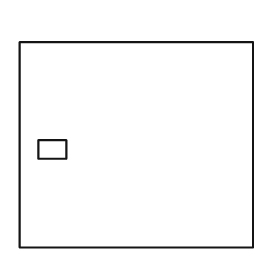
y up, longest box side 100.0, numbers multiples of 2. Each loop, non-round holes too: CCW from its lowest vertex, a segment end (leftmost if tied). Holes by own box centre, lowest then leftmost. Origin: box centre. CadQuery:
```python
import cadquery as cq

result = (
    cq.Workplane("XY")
    .moveTo(-50.0, -44.0)
    .lineTo(50.0, -44.0)
    .lineTo(50.0, 44.0)
    .lineTo(-50.0, 44.0)
    .close()
    .moveTo(-42.0, -6.0)
    .lineTo(-30.0, -6.0)
    .lineTo(-30.0, 2.0)
    .lineTo(-42.0, 2.0)
    .close()
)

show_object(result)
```